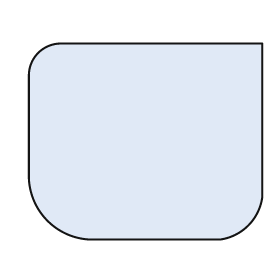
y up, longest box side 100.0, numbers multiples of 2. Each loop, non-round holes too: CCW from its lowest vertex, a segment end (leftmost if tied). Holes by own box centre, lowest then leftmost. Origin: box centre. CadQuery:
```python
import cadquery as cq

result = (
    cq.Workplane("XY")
    .moveTo(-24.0, -42.0)
    .lineTo(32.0, -42.0)
    .threePointArc((44.0, -36.0), (50.0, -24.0))
    .lineTo(50.0, 42.0)
    .lineTo(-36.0, 42.0)
    .threePointArc((-46.0, 38.0), (-50.0, 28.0))
    .lineTo(-50.0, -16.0)
    .threePointArc((-42.0, -34.0), (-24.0, -42.0))
    .close()
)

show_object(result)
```